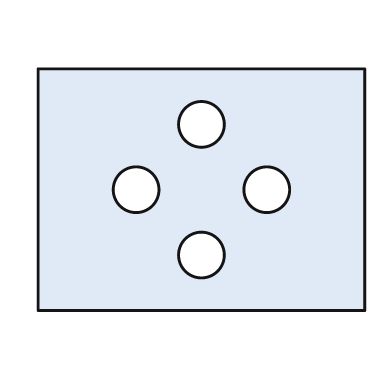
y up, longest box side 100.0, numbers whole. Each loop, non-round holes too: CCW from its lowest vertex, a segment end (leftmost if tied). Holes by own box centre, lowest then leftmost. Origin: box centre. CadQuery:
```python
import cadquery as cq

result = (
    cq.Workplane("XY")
    .moveTo(-50.0, -37.0)
    .lineTo(50.0, -37.0)
    .lineTo(50.0, 37.0)
    .lineTo(-50.0, 37.0)
    .close()
    .moveTo(0.0, -20.0)
    .circle(7.0)
    .moveTo(-20.0, 0.0)
    .circle(7.0)
    .moveTo(20.0, 0.0)
    .circle(7.0)
    .moveTo(0.0, 20.0)
    .circle(7.0)
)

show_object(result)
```